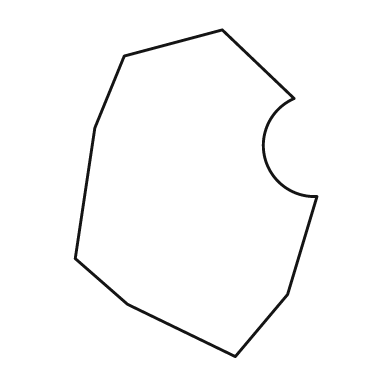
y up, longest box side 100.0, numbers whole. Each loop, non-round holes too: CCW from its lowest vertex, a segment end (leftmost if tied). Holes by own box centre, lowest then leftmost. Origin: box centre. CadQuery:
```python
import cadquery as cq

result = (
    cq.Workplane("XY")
    .moveTo(12.0, -50.0)
    .lineTo(28.0, -31.0)
    .lineTo(37.0, -1.0)
    .threePointArc((21.0, 11.0), (30.0, 29.0))
    .lineTo(8.0, 50.0)
    .lineTo(-22.0, 42.0)
    .lineTo(-31.0, 20.0)
    .lineTo(-37.0, -20.0)
    .lineTo(-21.0, -34.0)
    .close()
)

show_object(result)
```